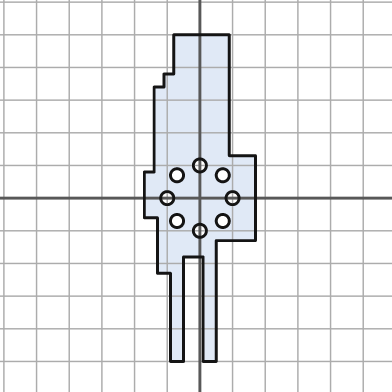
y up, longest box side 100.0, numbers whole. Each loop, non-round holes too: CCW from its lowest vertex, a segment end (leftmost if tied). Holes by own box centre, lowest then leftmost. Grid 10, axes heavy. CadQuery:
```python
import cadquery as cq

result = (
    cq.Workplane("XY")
    .moveTo(-9.0, -50.0)
    .lineTo(-5.0, -50.0)
    .lineTo(-5.0, -18.0)
    .lineTo(1.0, -18.0)
    .lineTo(1.0, -50.0)
    .lineTo(5.0, -50.0)
    .lineTo(5.0, -13.0)
    .lineTo(17.0, -13.0)
    .lineTo(17.0, 13.0)
    .lineTo(9.0, 13.0)
    .lineTo(9.0, 50.0)
    .lineTo(-8.0, 50.0)
    .lineTo(-8.0, 38.0)
    .lineTo(-11.0, 38.0)
    .lineTo(-11.0, 34.0)
    .lineTo(-14.0, 34.0)
    .lineTo(-14.0, 8.0)
    .lineTo(-17.0, 8.0)
    .lineTo(-17.0, -6.0)
    .lineTo(-13.0, -6.0)
    .lineTo(-13.0, -23.0)
    .lineTo(-9.0, -23.0)
    .close()
    .moveTo(0.0, -10.0)
    .circle(2.0)
    .moveTo(-7.0, -7.0)
    .circle(2.0)
    .moveTo(7.0, -7.0)
    .circle(2.0)
    .moveTo(-10.0, 0.0)
    .circle(2.0)
    .moveTo(10.0, 0.0)
    .circle(2.0)
    .moveTo(-7.0, 7.0)
    .circle(2.0)
    .moveTo(7.0, 7.0)
    .circle(2.0)
    .moveTo(0.0, 10.0)
    .circle(2.0)
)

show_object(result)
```